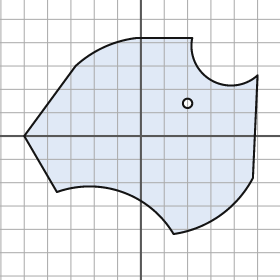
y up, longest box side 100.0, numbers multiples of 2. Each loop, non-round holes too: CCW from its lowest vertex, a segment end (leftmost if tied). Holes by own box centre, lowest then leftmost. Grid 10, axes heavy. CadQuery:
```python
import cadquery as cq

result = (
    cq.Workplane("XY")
    .moveTo(14.0, -42.0)
    .threePointArc((34.0, -34.0), (48.0, -18.0))
    .lineTo(50.0, 26.0)
    .threePointArc((30.0, 24.0), (22.0, 42.0))
    .lineTo(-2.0, 42.0)
    .threePointArc((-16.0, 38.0), (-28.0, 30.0))
    .lineTo(-50.0, 0.0)
    .lineTo(-36.0, -24.0)
    .threePointArc((-8.0, -24.0), (14.0, -42.0))
    .close()
    .moveTo(20.0, 14.0)
    .circle(2.0)
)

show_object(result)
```